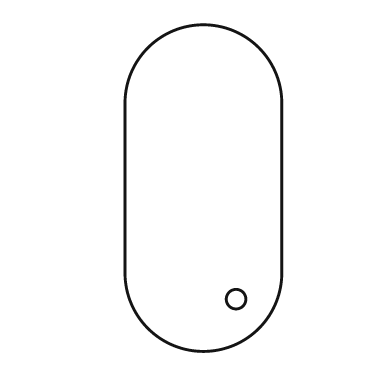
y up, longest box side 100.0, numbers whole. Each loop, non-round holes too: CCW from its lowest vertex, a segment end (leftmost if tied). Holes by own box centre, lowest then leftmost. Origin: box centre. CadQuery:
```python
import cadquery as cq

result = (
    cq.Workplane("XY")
    .moveTo(-24.0, -26.0)
    .threePointArc((0.0, -50.0), (24.0, -26.0))
    .lineTo(24.0, 26.0)
    .threePointArc((0.0, 50.0), (-24.0, 26.0))
    .close()
    .moveTo(10.0, -34.0)
    .circle(3.0)
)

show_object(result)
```